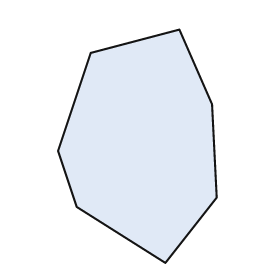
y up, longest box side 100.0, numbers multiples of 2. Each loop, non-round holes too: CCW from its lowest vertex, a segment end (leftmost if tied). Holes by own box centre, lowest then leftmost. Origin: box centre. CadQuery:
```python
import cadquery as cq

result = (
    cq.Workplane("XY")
    .moveTo(12.0, -50.0)
    .lineTo(34.0, -22.0)
    .lineTo(32.0, 18.0)
    .lineTo(18.0, 50.0)
    .lineTo(-20.0, 40.0)
    .lineTo(-34.0, -2.0)
    .lineTo(-26.0, -26.0)
    .close()
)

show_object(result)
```